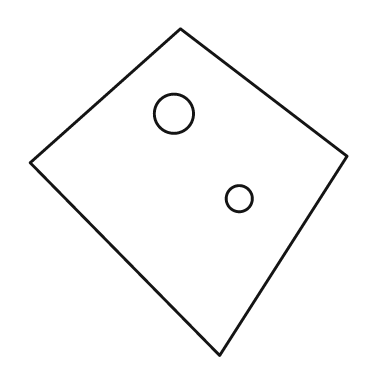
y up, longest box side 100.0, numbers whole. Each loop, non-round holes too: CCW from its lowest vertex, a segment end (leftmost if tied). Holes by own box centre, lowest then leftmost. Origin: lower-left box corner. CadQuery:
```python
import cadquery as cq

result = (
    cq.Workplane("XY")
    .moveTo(58.0, 0.0)
    .lineTo(97.0, 61.0)
    .lineTo(46.0, 100.0)
    .lineTo(0.0, 59.0)
    .close()
    .moveTo(64.0, 48.0)
    .circle(4.0)
    .moveTo(44.0, 74.0)
    .circle(6.0)
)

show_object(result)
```